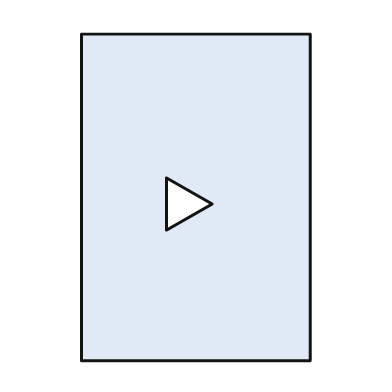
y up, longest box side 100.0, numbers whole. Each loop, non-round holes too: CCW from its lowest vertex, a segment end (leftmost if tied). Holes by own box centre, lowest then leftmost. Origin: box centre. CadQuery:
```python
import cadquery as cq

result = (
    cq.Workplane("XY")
    .moveTo(-35.0, -50.0)
    .lineTo(35.0, -50.0)
    .lineTo(35.0, 50.0)
    .lineTo(-35.0, 50.0)
    .close()
    .moveTo(-9.0, -10.0)
    .lineTo(5.0, -2.0)
    .lineTo(-9.0, 6.0)
    .close()
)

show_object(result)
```